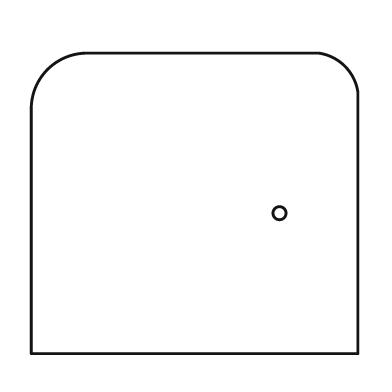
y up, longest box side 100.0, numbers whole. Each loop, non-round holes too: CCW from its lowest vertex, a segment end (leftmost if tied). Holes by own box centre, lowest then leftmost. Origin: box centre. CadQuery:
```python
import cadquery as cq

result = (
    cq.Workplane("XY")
    .moveTo(-50.0, -46.0)
    .lineTo(50.0, -46.0)
    .lineTo(50.0, 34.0)
    .threePointArc((46.0, 42.0), (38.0, 46.0))
    .lineTo(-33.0, 46.0)
    .threePointArc((-45.0, 41.0), (-50.0, 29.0))
    .close()
    .moveTo(26.0, -3.0)
    .circle(2.0)
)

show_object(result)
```